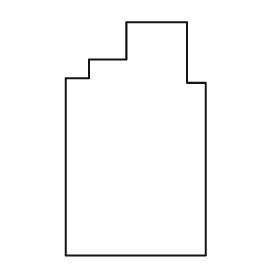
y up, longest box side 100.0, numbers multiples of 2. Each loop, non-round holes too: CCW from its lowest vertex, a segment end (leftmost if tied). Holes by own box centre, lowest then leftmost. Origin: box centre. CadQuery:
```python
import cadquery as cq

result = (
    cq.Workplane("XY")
    .moveTo(-30.0, -50.0)
    .lineTo(30.0, -50.0)
    .lineTo(30.0, 24.0)
    .lineTo(22.0, 24.0)
    .lineTo(22.0, 50.0)
    .lineTo(-4.0, 50.0)
    .lineTo(-4.0, 34.0)
    .lineTo(-20.0, 34.0)
    .lineTo(-20.0, 26.0)
    .lineTo(-30.0, 26.0)
    .close()
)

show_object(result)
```